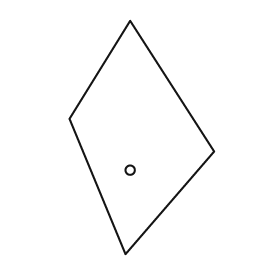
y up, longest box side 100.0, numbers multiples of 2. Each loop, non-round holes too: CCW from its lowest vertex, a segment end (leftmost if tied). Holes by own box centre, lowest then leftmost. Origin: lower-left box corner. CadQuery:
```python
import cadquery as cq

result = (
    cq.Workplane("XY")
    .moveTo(24.0, 0.0)
    .lineTo(62.0, 44.0)
    .lineTo(26.0, 100.0)
    .lineTo(0.0, 58.0)
    .close()
    .moveTo(26.0, 36.0)
    .circle(2.0)
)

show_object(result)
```